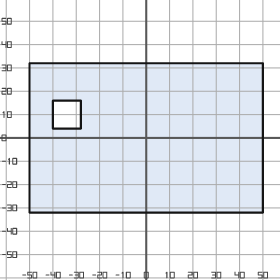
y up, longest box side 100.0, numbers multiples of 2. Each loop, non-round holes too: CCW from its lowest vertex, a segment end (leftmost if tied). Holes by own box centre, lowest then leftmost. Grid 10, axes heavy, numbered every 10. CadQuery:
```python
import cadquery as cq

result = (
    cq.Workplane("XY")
    .moveTo(-50.0, -32.0)
    .lineTo(50.0, -32.0)
    .lineTo(50.0, 32.0)
    .lineTo(-50.0, 32.0)
    .close()
    .moveTo(-40.0, 4.0)
    .lineTo(-28.0, 4.0)
    .lineTo(-28.0, 16.0)
    .lineTo(-40.0, 16.0)
    .close()
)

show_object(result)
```